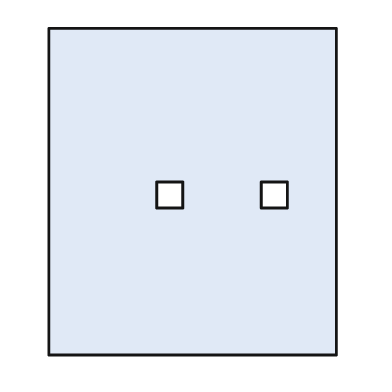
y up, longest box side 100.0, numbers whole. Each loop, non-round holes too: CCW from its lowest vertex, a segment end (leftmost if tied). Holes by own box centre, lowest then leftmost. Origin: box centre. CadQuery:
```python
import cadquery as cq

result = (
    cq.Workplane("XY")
    .moveTo(-44.0, -50.0)
    .lineTo(44.0, -50.0)
    .lineTo(44.0, 50.0)
    .lineTo(-44.0, 50.0)
    .close()
    .moveTo(-11.0, -5.0)
    .lineTo(-3.0, -5.0)
    .lineTo(-3.0, 3.0)
    .lineTo(-11.0, 3.0)
    .close()
    .moveTo(21.0, -5.0)
    .lineTo(29.0, -5.0)
    .lineTo(29.0, 3.0)
    .lineTo(21.0, 3.0)
    .close()
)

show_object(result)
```